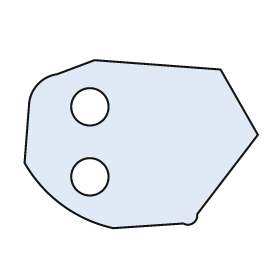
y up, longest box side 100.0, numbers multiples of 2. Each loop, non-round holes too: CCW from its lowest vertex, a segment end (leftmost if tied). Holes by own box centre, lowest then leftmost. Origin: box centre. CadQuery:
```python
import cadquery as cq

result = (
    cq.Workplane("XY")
    .moveTo(-12.0, -36.0)
    .lineTo(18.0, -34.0)
    .threePointArc((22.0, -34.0), (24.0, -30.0))
    .lineTo(50.0, 4.0)
    .lineTo(34.0, 32.0)
    .lineTo(-20.0, 36.0)
    .lineTo(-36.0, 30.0)
    .threePointArc((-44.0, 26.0), (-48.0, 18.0))
    .lineTo(-50.0, -8.0)
    .threePointArc((-34.0, -26.0), (-12.0, -36.0))
    .close()
    .moveTo(-22.0, -14.0)
    .circle(8.0)
    .moveTo(-22.0, 16.0)
    .circle(8.0)
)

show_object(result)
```